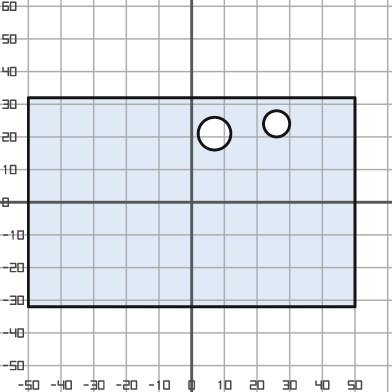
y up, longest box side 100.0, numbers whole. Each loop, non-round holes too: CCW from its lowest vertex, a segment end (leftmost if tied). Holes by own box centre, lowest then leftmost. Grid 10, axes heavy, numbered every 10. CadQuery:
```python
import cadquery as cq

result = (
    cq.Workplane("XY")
    .moveTo(-50.0, -32.0)
    .lineTo(50.0, -32.0)
    .lineTo(50.0, 32.0)
    .lineTo(-50.0, 32.0)
    .close()
    .moveTo(7.0, 21.0)
    .circle(5.0)
    .moveTo(26.0, 24.0)
    .circle(4.0)
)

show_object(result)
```